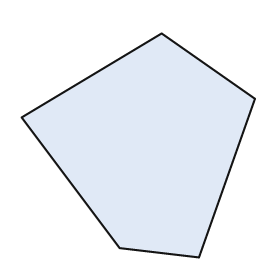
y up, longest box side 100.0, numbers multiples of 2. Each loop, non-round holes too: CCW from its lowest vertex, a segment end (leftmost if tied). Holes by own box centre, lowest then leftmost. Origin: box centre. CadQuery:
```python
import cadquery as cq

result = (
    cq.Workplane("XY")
    .moveTo(26.0, -48.0)
    .lineTo(50.0, 20.0)
    .lineTo(10.0, 48.0)
    .lineTo(-50.0, 12.0)
    .lineTo(-8.0, -44.0)
    .close()
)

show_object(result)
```